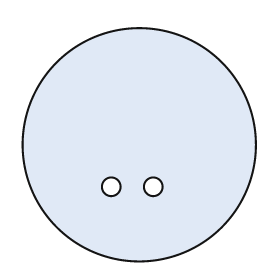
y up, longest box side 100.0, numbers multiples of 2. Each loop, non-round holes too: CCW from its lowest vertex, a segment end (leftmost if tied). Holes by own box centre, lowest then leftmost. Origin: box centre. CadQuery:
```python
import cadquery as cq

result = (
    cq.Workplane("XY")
    .moveTo(0.0, 0.0)
    .circle(50.0)
    .moveTo(-12.0, -18.0)
    .circle(4.0)
    .moveTo(6.0, -18.0)
    .circle(4.0)
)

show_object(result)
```